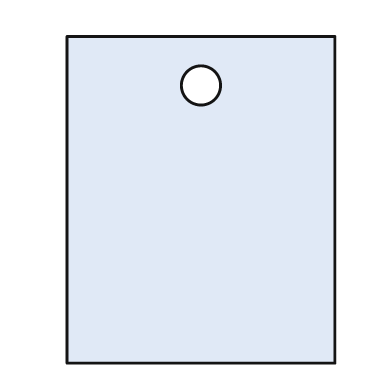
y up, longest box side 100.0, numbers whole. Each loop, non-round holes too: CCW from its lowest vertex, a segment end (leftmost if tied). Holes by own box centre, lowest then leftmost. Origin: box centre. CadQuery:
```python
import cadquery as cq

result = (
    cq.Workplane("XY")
    .moveTo(-41.0, -50.0)
    .lineTo(41.0, -50.0)
    .lineTo(41.0, 50.0)
    .lineTo(-41.0, 50.0)
    .close()
    .moveTo(0.0, 35.0)
    .circle(6.0)
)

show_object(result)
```